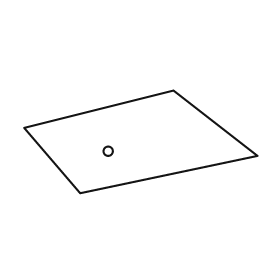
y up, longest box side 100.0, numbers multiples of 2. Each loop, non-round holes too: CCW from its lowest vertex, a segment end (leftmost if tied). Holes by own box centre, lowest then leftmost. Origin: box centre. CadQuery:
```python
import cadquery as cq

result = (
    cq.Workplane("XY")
    .moveTo(-26.0, -22.0)
    .lineTo(50.0, -6.0)
    .lineTo(14.0, 22.0)
    .lineTo(-50.0, 6.0)
    .close()
    .moveTo(-14.0, -4.0)
    .circle(2.0)
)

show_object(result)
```